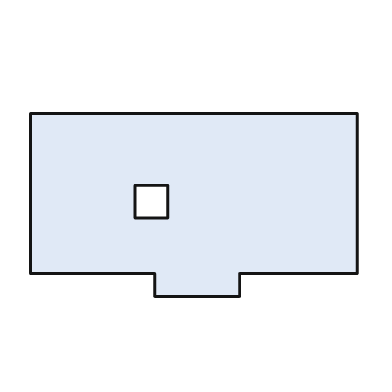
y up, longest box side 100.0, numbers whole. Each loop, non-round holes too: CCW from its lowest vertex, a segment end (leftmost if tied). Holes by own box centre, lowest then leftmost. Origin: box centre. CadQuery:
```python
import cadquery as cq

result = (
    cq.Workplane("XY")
    .moveTo(-12.0, -28.0)
    .lineTo(14.0, -28.0)
    .lineTo(14.0, -21.0)
    .lineTo(50.0, -21.0)
    .lineTo(50.0, 28.0)
    .lineTo(-50.0, 28.0)
    .lineTo(-50.0, -21.0)
    .lineTo(-12.0, -21.0)
    .close()
    .moveTo(-18.0, -4.0)
    .lineTo(-8.0, -4.0)
    .lineTo(-8.0, 6.0)
    .lineTo(-18.0, 6.0)
    .close()
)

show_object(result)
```